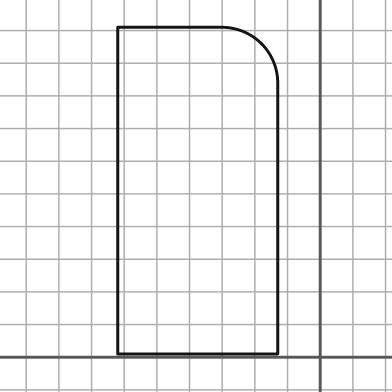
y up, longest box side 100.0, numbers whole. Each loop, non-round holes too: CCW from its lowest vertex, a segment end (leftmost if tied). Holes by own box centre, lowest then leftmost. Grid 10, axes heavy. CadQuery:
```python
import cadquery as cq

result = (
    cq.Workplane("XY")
    .moveTo(-62.0, 1.0)
    .lineTo(-13.0, 1.0)
    .lineTo(-13.0, 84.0)
    .threePointArc((-18.0, 96.0), (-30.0, 101.0))
    .lineTo(-62.0, 101.0)
    .close()
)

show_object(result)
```